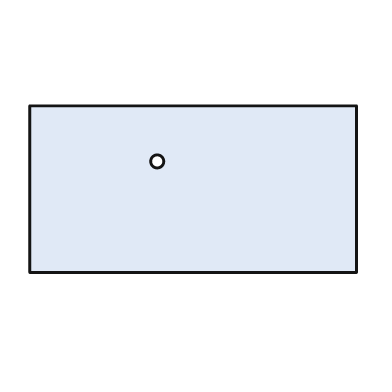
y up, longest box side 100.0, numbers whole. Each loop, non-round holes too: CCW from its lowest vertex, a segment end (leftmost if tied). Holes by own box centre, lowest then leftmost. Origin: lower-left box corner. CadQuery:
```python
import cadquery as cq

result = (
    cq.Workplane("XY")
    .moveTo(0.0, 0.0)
    .lineTo(100.0, 0.0)
    .lineTo(100.0, 51.0)
    .lineTo(0.0, 51.0)
    .close()
    .moveTo(39.0, 34.0)
    .circle(2.0)
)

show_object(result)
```